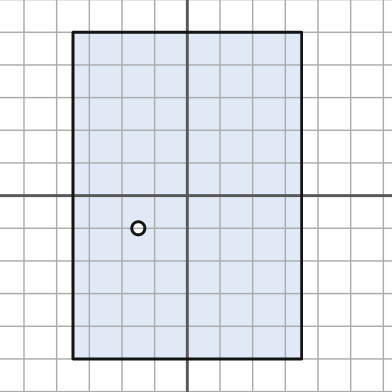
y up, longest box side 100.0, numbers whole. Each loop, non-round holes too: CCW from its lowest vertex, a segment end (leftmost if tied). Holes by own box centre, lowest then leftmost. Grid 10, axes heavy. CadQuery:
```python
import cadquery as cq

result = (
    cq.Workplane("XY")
    .moveTo(-35.0, -50.0)
    .lineTo(35.0, -50.0)
    .lineTo(35.0, 50.0)
    .lineTo(-35.0, 50.0)
    .close()
    .moveTo(-15.0, -10.0)
    .circle(2.0)
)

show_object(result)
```